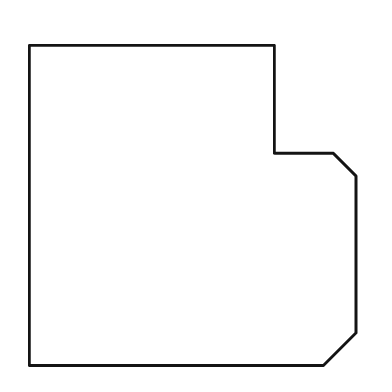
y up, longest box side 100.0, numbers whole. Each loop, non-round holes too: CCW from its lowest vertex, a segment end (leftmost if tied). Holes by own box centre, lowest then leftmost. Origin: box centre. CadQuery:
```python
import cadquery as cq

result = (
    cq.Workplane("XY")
    .moveTo(-50.0, -49.0)
    .lineTo(40.0, -49.0)
    .lineTo(50.0, -39.0)
    .lineTo(50.0, 9.0)
    .lineTo(43.0, 16.0)
    .lineTo(25.0, 16.0)
    .lineTo(25.0, 49.0)
    .lineTo(-50.0, 49.0)
    .close()
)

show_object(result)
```